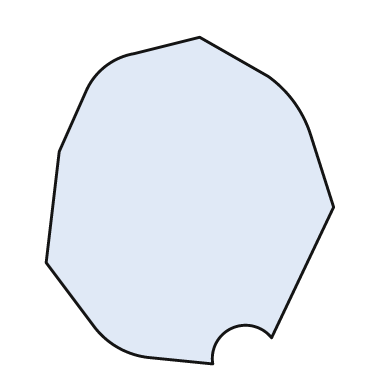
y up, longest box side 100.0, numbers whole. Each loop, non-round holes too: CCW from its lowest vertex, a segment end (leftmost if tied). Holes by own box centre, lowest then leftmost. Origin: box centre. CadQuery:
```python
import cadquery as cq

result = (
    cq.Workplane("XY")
    .moveTo(7.0, -50.0)
    .threePointArc((13.0, -39.0), (25.0, -42.0))
    .lineTo(44.0, -2.0)
    .lineTo(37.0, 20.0)
    .threePointArc((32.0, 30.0), (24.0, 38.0))
    .lineTo(3.0, 50.0)
    .lineTo(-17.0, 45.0)
    .threePointArc((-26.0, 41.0), (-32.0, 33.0))
    .lineTo(-40.0, 15.0)
    .lineTo(-44.0, -19.0)
    .lineTo(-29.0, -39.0)
    .threePointArc((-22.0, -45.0), (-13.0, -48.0))
    .close()
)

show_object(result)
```